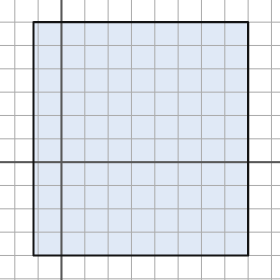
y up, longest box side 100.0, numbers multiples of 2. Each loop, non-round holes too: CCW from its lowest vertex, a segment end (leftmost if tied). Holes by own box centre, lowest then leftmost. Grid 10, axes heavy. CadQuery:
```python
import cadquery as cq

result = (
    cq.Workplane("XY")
    .moveTo(-12.0, -40.0)
    .lineTo(80.0, -40.0)
    .lineTo(80.0, 60.0)
    .lineTo(-12.0, 60.0)
    .close()
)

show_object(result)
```